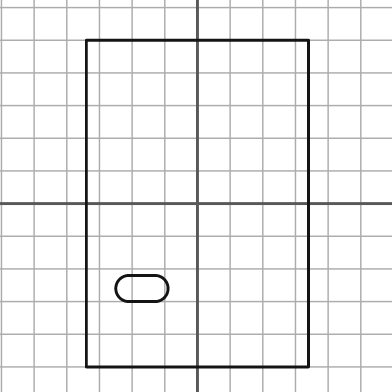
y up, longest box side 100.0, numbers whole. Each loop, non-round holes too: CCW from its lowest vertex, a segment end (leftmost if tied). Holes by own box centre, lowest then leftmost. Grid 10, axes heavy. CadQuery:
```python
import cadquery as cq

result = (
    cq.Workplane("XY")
    .moveTo(-34.0, -50.0)
    .lineTo(34.0, -50.0)
    .lineTo(34.0, 50.0)
    .lineTo(-34.0, 50.0)
    .close()
    .moveTo(-21.0, -30.0)
    .lineTo(-13.0, -30.0)
    .threePointArc((-9.0, -26.0), (-13.0, -22.0))
    .lineTo(-21.0, -22.0)
    .threePointArc((-25.0, -26.0), (-21.0, -30.0))
    .close()
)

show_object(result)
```